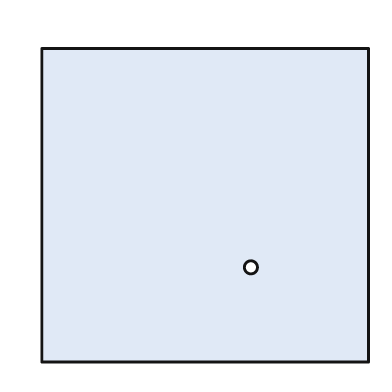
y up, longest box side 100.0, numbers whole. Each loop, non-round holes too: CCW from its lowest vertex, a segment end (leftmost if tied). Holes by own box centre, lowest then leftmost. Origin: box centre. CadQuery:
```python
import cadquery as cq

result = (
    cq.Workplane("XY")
    .moveTo(-50.0, -48.0)
    .lineTo(50.0, -48.0)
    .lineTo(50.0, 48.0)
    .lineTo(-50.0, 48.0)
    .close()
    .moveTo(14.0, -19.0)
    .circle(2.0)
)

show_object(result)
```